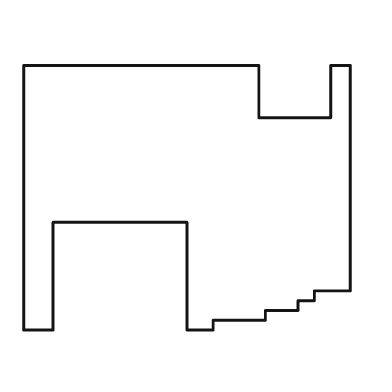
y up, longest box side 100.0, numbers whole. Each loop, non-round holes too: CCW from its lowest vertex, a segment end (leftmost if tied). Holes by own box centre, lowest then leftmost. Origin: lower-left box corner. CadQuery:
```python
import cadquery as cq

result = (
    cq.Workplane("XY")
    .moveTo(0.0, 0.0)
    .lineTo(9.0, 0.0)
    .lineTo(9.0, 33.0)
    .lineTo(50.0, 33.0)
    .lineTo(50.0, 0.0)
    .lineTo(58.0, 0.0)
    .lineTo(58.0, 3.0)
    .lineTo(74.0, 3.0)
    .lineTo(74.0, 6.0)
    .lineTo(84.0, 6.0)
    .lineTo(84.0, 9.0)
    .lineTo(89.0, 9.0)
    .lineTo(89.0, 12.0)
    .lineTo(100.0, 12.0)
    .lineTo(100.0, 81.0)
    .lineTo(94.0, 81.0)
    .lineTo(94.0, 65.0)
    .lineTo(72.0, 65.0)
    .lineTo(72.0, 81.0)
    .lineTo(0.0, 81.0)
    .close()
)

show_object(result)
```